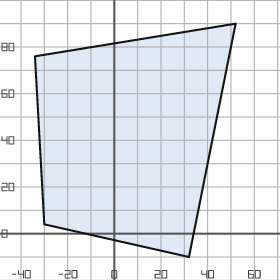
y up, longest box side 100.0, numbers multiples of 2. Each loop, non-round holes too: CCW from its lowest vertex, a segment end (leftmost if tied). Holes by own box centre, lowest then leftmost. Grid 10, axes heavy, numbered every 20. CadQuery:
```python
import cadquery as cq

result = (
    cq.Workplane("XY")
    .moveTo(32.0, -10.0)
    .lineTo(52.0, 90.0)
    .lineTo(-34.0, 76.0)
    .lineTo(-30.0, 4.0)
    .close()
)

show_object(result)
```